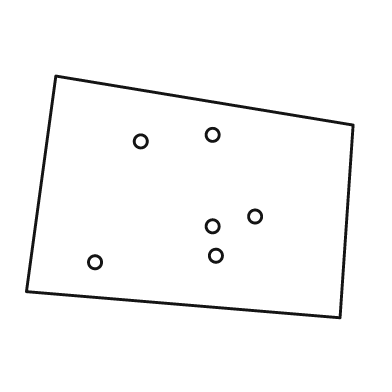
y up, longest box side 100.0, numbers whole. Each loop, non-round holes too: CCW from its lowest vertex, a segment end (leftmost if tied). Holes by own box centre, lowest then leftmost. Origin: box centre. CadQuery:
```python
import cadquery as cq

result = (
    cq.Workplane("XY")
    .moveTo(46.0, -37.0)
    .lineTo(50.0, 22.0)
    .lineTo(-41.0, 37.0)
    .lineTo(-50.0, -29.0)
    .close()
    .moveTo(-29.0, -20.0)
    .circle(2.0)
    .moveTo(8.0, -18.0)
    .circle(2.0)
    .moveTo(7.0, -9.0)
    .circle(2.0)
    .moveTo(20.0, -6.0)
    .circle(2.0)
    .moveTo(-15.0, 17.0)
    .circle(2.0)
    .moveTo(7.0, 19.0)
    .circle(2.0)
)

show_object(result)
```